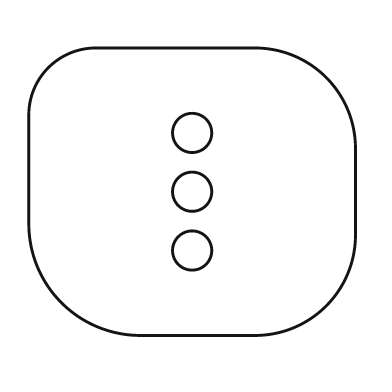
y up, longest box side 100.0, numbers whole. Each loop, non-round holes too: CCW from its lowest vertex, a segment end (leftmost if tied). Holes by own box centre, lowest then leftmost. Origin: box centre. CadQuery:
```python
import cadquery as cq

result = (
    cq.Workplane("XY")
    .moveTo(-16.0, -44.0)
    .lineTo(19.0, -44.0)
    .threePointArc((41.0, -35.0), (50.0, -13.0))
    .lineTo(50.0, 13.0)
    .threePointArc((41.0, 35.0), (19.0, 44.0))
    .lineTo(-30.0, 44.0)
    .threePointArc((-44.0, 38.0), (-50.0, 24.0))
    .lineTo(-50.0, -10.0)
    .threePointArc((-40.0, -34.0), (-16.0, -44.0))
    .close()
    .moveTo(0.0, -18.0)
    .circle(6.0)
    .moveTo(0.0, 0.0)
    .circle(6.0)
    .moveTo(0.0, 18.0)
    .circle(6.0)
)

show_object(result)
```